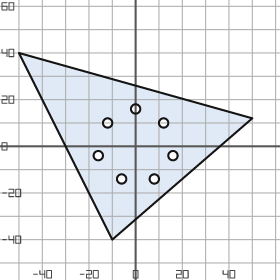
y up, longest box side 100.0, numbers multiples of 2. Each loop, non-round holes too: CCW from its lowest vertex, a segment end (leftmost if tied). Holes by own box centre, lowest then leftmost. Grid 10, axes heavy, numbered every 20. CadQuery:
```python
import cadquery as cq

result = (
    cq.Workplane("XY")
    .moveTo(-10.0, -40.0)
    .lineTo(50.0, 12.0)
    .lineTo(-50.0, 40.0)
    .close()
    .moveTo(-6.0, -14.0)
    .circle(2.0)
    .moveTo(8.0, -14.0)
    .circle(2.0)
    .moveTo(-16.0, -4.0)
    .circle(2.0)
    .moveTo(16.0, -4.0)
    .circle(2.0)
    .moveTo(-12.0, 10.0)
    .circle(2.0)
    .moveTo(12.0, 10.0)
    .circle(2.0)
    .moveTo(0.0, 16.0)
    .circle(2.0)
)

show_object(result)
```